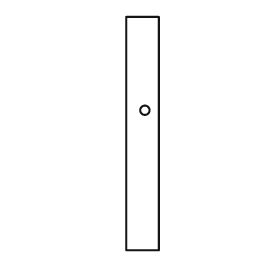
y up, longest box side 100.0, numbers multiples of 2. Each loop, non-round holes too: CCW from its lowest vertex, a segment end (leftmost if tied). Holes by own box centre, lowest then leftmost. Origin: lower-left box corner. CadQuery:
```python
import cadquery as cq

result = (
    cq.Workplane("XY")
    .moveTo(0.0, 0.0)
    .lineTo(14.0, 0.0)
    .lineTo(14.0, 100.0)
    .lineTo(0.0, 100.0)
    .close()
    .moveTo(8.0, 60.0)
    .circle(2.0)
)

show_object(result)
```